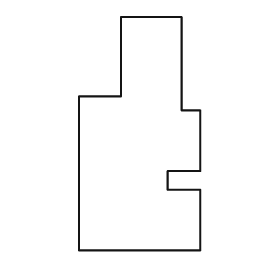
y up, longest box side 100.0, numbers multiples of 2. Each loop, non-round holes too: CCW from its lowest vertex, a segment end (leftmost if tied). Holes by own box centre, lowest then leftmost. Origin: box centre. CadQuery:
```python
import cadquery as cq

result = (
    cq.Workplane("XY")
    .moveTo(-26.0, -50.0)
    .lineTo(26.0, -50.0)
    .lineTo(26.0, -24.0)
    .lineTo(12.0, -24.0)
    .lineTo(12.0, -16.0)
    .lineTo(26.0, -16.0)
    .lineTo(26.0, 10.0)
    .lineTo(18.0, 10.0)
    .lineTo(18.0, 50.0)
    .lineTo(-8.0, 50.0)
    .lineTo(-8.0, 16.0)
    .lineTo(-26.0, 16.0)
    .close()
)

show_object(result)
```